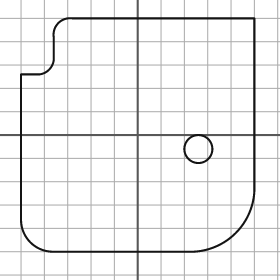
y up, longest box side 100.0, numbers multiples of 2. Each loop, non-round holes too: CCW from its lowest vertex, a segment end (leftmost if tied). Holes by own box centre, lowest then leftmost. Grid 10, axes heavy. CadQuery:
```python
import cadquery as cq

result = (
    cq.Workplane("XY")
    .moveTo(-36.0, -50.0)
    .lineTo(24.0, -50.0)
    .threePointArc((42.0, -42.0), (50.0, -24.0))
    .lineTo(50.0, 50.0)
    .lineTo(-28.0, 50.0)
    .threePointArc((-34.0, 48.0), (-36.0, 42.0))
    .lineTo(-36.0, 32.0)
    .threePointArc((-38.0, 28.0), (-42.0, 26.0))
    .lineTo(-50.0, 26.0)
    .lineTo(-50.0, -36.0)
    .threePointArc((-46.0, -46.0), (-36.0, -50.0))
    .close()
    .moveTo(26.0, -6.0)
    .circle(6.0)
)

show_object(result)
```